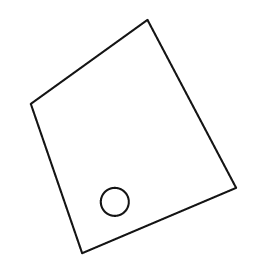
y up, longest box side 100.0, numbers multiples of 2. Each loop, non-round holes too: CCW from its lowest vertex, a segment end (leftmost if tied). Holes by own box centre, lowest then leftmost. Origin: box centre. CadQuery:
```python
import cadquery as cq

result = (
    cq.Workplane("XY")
    .moveTo(-22.0, -50.0)
    .lineTo(44.0, -22.0)
    .lineTo(6.0, 50.0)
    .lineTo(-44.0, 14.0)
    .close()
    .moveTo(-8.0, -28.0)
    .circle(6.0)
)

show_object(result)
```